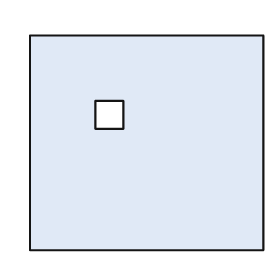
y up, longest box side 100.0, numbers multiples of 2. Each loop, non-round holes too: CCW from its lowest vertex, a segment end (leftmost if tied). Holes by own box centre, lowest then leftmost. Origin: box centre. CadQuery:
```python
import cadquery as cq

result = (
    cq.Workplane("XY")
    .moveTo(-50.0, -46.0)
    .lineTo(50.0, -46.0)
    .lineTo(50.0, 46.0)
    .lineTo(-50.0, 46.0)
    .close()
    .moveTo(-22.0, 6.0)
    .lineTo(-10.0, 6.0)
    .lineTo(-10.0, 18.0)
    .lineTo(-22.0, 18.0)
    .close()
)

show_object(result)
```